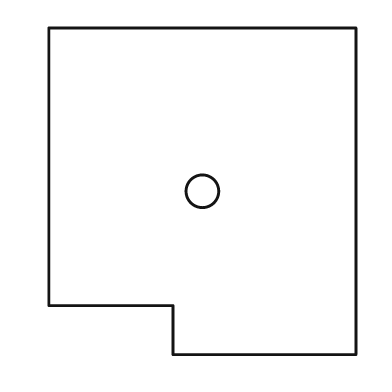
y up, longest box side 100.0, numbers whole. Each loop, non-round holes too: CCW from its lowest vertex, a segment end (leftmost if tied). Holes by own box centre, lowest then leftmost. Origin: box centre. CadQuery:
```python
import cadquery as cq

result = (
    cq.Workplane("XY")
    .moveTo(-9.0, -50.0)
    .lineTo(47.0, -50.0)
    .lineTo(47.0, 50.0)
    .lineTo(-47.0, 50.0)
    .lineTo(-47.0, -35.0)
    .lineTo(-9.0, -35.0)
    .close()
    .moveTo(0.0, 0.0)
    .circle(5.0)
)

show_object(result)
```